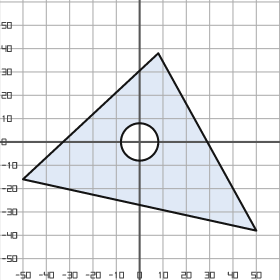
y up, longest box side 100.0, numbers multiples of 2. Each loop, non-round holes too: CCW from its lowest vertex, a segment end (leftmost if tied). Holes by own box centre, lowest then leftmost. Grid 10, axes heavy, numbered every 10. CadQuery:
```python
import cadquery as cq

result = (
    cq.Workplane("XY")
    .moveTo(50.0, -38.0)
    .lineTo(8.0, 38.0)
    .lineTo(-50.0, -16.0)
    .close()
    .moveTo(0.0, 0.0)
    .circle(8.0)
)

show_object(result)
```